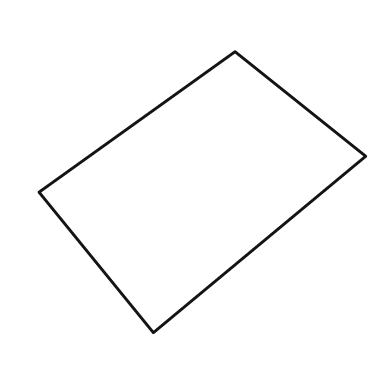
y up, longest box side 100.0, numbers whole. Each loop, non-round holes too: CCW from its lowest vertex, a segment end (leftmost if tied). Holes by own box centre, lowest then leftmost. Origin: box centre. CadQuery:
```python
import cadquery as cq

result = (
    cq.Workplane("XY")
    .moveTo(-15.0, -43.0)
    .lineTo(50.0, 11.0)
    .lineTo(10.0, 43.0)
    .lineTo(-50.0, 0.0)
    .close()
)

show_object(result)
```